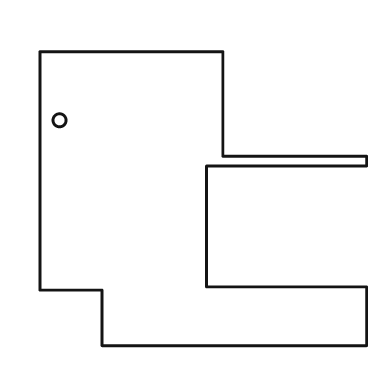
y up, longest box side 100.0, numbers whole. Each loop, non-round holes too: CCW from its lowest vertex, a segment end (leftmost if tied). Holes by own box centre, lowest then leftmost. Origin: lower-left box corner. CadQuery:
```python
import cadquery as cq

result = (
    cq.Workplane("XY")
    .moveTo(19.0, 0.0)
    .lineTo(100.0, 0.0)
    .lineTo(100.0, 18.0)
    .lineTo(51.0, 18.0)
    .lineTo(51.0, 55.0)
    .lineTo(100.0, 55.0)
    .lineTo(100.0, 58.0)
    .lineTo(56.0, 58.0)
    .lineTo(56.0, 90.0)
    .lineTo(0.0, 90.0)
    .lineTo(0.0, 17.0)
    .lineTo(19.0, 17.0)
    .close()
    .moveTo(6.0, 69.0)
    .circle(2.0)
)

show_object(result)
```